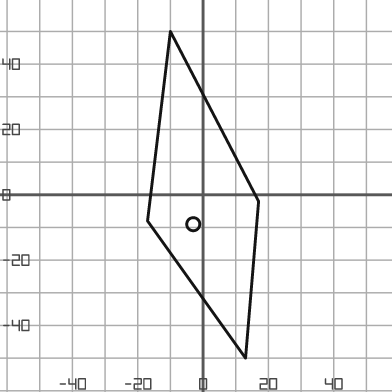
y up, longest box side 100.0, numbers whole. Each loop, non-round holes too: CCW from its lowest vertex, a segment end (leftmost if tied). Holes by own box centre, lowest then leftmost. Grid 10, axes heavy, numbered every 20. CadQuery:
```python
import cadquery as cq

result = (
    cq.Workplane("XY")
    .moveTo(13.0, -50.0)
    .lineTo(17.0, -2.0)
    .lineTo(-10.0, 50.0)
    .lineTo(-17.0, -8.0)
    .close()
    .moveTo(-3.0, -9.0)
    .circle(2.0)
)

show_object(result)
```